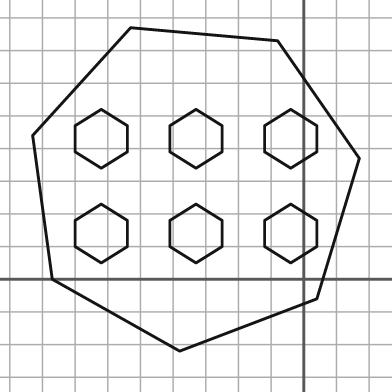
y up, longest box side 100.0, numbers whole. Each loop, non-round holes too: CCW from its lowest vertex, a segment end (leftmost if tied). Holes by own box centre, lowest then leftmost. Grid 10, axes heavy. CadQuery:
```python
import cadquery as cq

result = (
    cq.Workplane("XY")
    .moveTo(-38.0, -22.0)
    .lineTo(4.0, -6.0)
    .lineTo(17.0, 37.0)
    .lineTo(-8.0, 73.0)
    .lineTo(-53.0, 77.0)
    .lineTo(-83.0, 44.0)
    .lineTo(-77.0, 0.0)
    .close()
    .moveTo(-62.0, 5.0)
    .lineTo(-54.0, 10.0)
    .lineTo(-54.0, 18.0)
    .lineTo(-62.0, 23.0)
    .lineTo(-70.0, 18.0)
    .lineTo(-70.0, 10.0)
    .close()
    .moveTo(-33.0, 5.0)
    .lineTo(-25.0, 10.0)
    .lineTo(-25.0, 18.0)
    .lineTo(-33.0, 23.0)
    .lineTo(-41.0, 18.0)
    .lineTo(-41.0, 10.0)
    .close()
    .moveTo(-4.0, 5.0)
    .lineTo(4.0, 10.0)
    .lineTo(4.0, 18.0)
    .lineTo(-4.0, 23.0)
    .lineTo(-12.0, 18.0)
    .lineTo(-12.0, 10.0)
    .close()
    .moveTo(-62.0, 34.0)
    .lineTo(-54.0, 39.0)
    .lineTo(-54.0, 47.0)
    .lineTo(-62.0, 52.0)
    .lineTo(-70.0, 47.0)
    .lineTo(-70.0, 39.0)
    .close()
    .moveTo(-33.0, 34.0)
    .lineTo(-25.0, 39.0)
    .lineTo(-25.0, 47.0)
    .lineTo(-33.0, 52.0)
    .lineTo(-41.0, 47.0)
    .lineTo(-41.0, 39.0)
    .close()
    .moveTo(-4.0, 34.0)
    .lineTo(4.0, 39.0)
    .lineTo(4.0, 47.0)
    .lineTo(-4.0, 52.0)
    .lineTo(-12.0, 47.0)
    .lineTo(-12.0, 39.0)
    .close()
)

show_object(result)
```